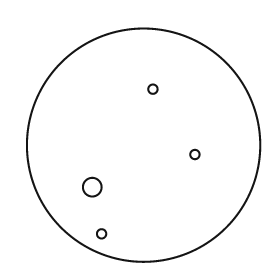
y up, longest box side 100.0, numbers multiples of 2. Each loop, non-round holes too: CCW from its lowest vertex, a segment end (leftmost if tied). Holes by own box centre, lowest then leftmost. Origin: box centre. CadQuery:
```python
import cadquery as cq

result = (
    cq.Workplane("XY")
    .moveTo(0.0, 0.0)
    .circle(50.0)
    .moveTo(-18.0, -38.0)
    .circle(2.0)
    .moveTo(-22.0, -18.0)
    .circle(4.0)
    .moveTo(22.0, -4.0)
    .circle(2.0)
    .moveTo(4.0, 24.0)
    .circle(2.0)
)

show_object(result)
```